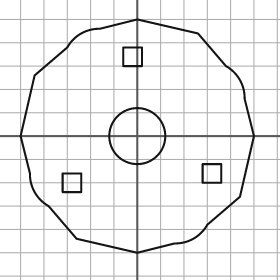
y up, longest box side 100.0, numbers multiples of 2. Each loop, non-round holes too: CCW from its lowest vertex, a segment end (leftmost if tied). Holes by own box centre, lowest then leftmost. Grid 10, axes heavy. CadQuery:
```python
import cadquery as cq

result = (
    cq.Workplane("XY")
    .moveTo(0.0, -50.0)
    .lineTo(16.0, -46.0)
    .threePointArc((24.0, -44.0), (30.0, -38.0))
    .lineTo(44.0, -26.0)
    .lineTo(50.0, 0.0)
    .lineTo(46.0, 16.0)
    .threePointArc((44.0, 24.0), (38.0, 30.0))
    .lineTo(26.0, 44.0)
    .lineTo(0.0, 50.0)
    .lineTo(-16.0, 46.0)
    .threePointArc((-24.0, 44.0), (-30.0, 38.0))
    .lineTo(-44.0, 26.0)
    .lineTo(-50.0, 0.0)
    .lineTo(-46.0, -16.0)
    .threePointArc((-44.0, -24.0), (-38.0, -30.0))
    .lineTo(-26.0, -44.0)
    .close()
    .moveTo(-32.0, -24.0)
    .lineTo(-24.0, -24.0)
    .lineTo(-24.0, -16.0)
    .lineTo(-32.0, -16.0)
    .close()
    .moveTo(28.0, -20.0)
    .lineTo(36.0, -20.0)
    .lineTo(36.0, -12.0)
    .lineTo(28.0, -12.0)
    .close()
    .moveTo(0.0, 0.0)
    .circle(12.0)
    .moveTo(-6.0, 30.0)
    .lineTo(2.0, 30.0)
    .lineTo(2.0, 38.0)
    .lineTo(-6.0, 38.0)
    .close()
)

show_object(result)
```